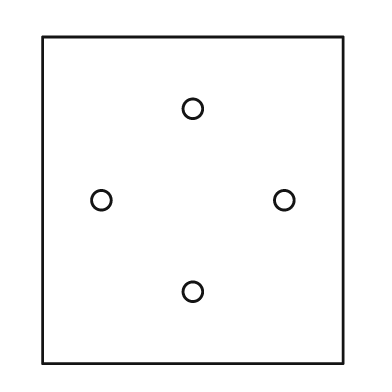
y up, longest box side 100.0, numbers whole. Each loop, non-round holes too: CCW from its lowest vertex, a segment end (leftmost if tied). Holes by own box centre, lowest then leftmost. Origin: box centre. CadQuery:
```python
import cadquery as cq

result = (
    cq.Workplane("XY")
    .moveTo(-46.0, -50.0)
    .lineTo(46.0, -50.0)
    .lineTo(46.0, 50.0)
    .lineTo(-46.0, 50.0)
    .close()
    .moveTo(0.0, -28.0)
    .circle(3.0)
    .moveTo(-28.0, 0.0)
    .circle(3.0)
    .moveTo(28.0, 0.0)
    .circle(3.0)
    .moveTo(0.0, 28.0)
    .circle(3.0)
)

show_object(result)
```